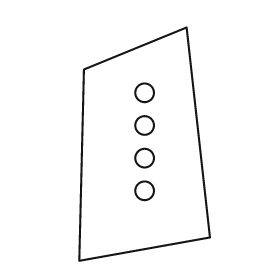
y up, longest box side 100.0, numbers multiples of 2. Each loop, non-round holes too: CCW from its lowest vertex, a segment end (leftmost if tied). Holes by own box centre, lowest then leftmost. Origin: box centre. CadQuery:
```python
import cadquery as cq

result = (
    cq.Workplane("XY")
    .moveTo(-28.0, -50.0)
    .lineTo(28.0, -40.0)
    .lineTo(18.0, 50.0)
    .lineTo(-26.0, 32.0)
    .close()
    .moveTo(0.0, -20.0)
    .circle(4.0)
    .moveTo(0.0, -6.0)
    .circle(4.0)
    .moveTo(0.0, 8.0)
    .circle(4.0)
    .moveTo(0.0, 22.0)
    .circle(4.0)
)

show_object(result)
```